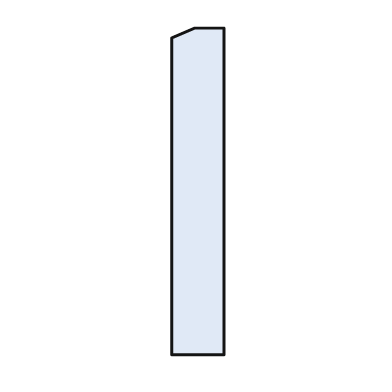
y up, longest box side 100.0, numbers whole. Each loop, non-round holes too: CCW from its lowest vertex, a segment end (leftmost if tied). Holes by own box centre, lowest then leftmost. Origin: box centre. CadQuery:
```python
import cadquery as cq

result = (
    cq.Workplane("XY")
    .moveTo(-8.0, -50.0)
    .lineTo(8.0, -50.0)
    .lineTo(8.0, 50.0)
    .lineTo(-1.0, 50.0)
    .lineTo(-8.0, 47.0)
    .close()
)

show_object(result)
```